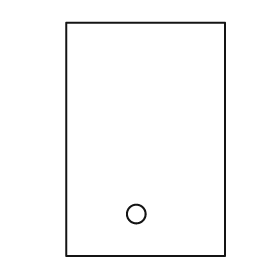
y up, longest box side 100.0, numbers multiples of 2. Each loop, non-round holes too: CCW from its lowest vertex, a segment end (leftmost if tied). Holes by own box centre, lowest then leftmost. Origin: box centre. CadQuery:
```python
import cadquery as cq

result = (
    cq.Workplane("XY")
    .moveTo(-34.0, -50.0)
    .lineTo(34.0, -50.0)
    .lineTo(34.0, 50.0)
    .lineTo(-34.0, 50.0)
    .close()
    .moveTo(-4.0, -32.0)
    .circle(4.0)
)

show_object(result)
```